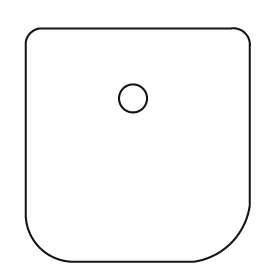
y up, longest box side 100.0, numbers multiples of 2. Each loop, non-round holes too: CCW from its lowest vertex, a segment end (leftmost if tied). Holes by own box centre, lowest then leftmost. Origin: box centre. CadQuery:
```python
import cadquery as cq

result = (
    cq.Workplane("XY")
    .moveTo(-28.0, -50.0)
    .lineTo(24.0, -50.0)
    .threePointArc((40.0, -42.0), (48.0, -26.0))
    .lineTo(48.0, 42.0)
    .threePointArc((46.0, 48.0), (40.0, 50.0))
    .lineTo(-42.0, 50.0)
    .threePointArc((-46.0, 48.0), (-48.0, 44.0))
    .lineTo(-48.0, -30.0)
    .threePointArc((-42.0, -44.0), (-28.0, -50.0))
    .close()
    .moveTo(-2.0, 20.0)
    .circle(6.0)
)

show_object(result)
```